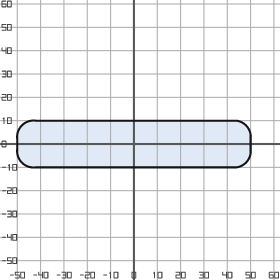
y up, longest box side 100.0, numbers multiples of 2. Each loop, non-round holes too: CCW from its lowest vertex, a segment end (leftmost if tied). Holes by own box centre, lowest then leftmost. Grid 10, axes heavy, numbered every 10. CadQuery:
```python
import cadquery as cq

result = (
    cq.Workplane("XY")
    .moveTo(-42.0, -10.0)
    .lineTo(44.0, -10.0)
    .threePointArc((48.0, -8.0), (50.0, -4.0))
    .lineTo(50.0, 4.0)
    .threePointArc((48.0, 8.0), (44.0, 10.0))
    .lineTo(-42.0, 10.0)
    .threePointArc((-48.0, 8.0), (-50.0, 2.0))
    .lineTo(-50.0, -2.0)
    .threePointArc((-48.0, -8.0), (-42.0, -10.0))
    .close()
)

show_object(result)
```